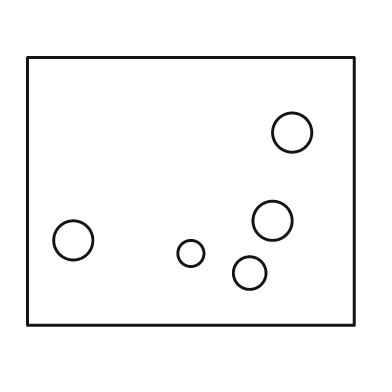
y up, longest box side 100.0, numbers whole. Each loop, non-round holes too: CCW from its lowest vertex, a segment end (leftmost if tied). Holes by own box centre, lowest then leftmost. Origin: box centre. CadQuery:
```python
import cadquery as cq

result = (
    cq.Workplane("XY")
    .moveTo(-50.0, -41.0)
    .lineTo(50.0, -41.0)
    .lineTo(50.0, 41.0)
    .lineTo(-50.0, 41.0)
    .close()
    .moveTo(18.0, -25.0)
    .circle(5.0)
    .moveTo(0.0, -19.0)
    .circle(4.0)
    .moveTo(-36.0, -15.0)
    .circle(6.0)
    .moveTo(25.0, -9.0)
    .circle(6.0)
    .moveTo(31.0, 18.0)
    .circle(6.0)
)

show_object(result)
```